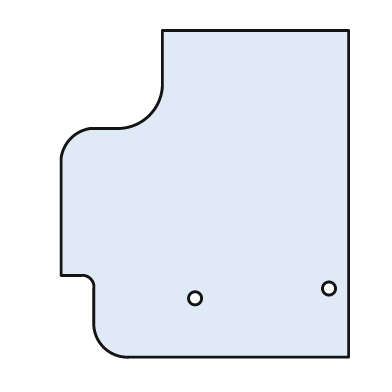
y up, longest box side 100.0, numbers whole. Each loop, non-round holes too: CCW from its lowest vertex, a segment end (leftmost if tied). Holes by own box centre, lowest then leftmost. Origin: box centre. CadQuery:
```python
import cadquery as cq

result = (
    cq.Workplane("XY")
    .moveTo(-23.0, -50.0)
    .lineTo(44.0, -50.0)
    .lineTo(44.0, 50.0)
    .lineTo(-13.0, 50.0)
    .lineTo(-13.0, 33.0)
    .threePointArc((-17.0, 24.0), (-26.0, 20.0))
    .lineTo(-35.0, 20.0)
    .threePointArc((-41.0, 17.0), (-44.0, 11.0))
    .lineTo(-44.0, -25.0)
    .lineTo(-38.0, -25.0)
    .threePointArc((-35.0, -26.0), (-34.0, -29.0))
    .lineTo(-34.0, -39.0)
    .threePointArc((-31.0, -47.0), (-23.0, -50.0))
    .close()
    .moveTo(-3.0, -32.0)
    .circle(2.0)
    .moveTo(38.0, -29.0)
    .circle(2.0)
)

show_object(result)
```